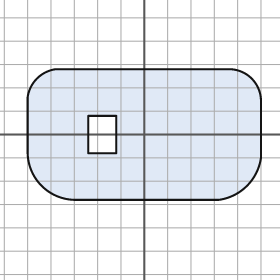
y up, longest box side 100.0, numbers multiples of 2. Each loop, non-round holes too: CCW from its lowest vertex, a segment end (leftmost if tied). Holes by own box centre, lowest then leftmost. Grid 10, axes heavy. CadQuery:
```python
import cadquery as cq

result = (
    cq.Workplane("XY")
    .moveTo(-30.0, -28.0)
    .lineTo(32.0, -28.0)
    .threePointArc((44.0, -22.0), (50.0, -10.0))
    .lineTo(50.0, 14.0)
    .threePointArc((46.0, 24.0), (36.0, 28.0))
    .lineTo(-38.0, 28.0)
    .threePointArc((-46.0, 24.0), (-50.0, 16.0))
    .lineTo(-50.0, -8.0)
    .threePointArc((-44.0, -22.0), (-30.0, -28.0))
    .close()
    .moveTo(-24.0, -8.0)
    .lineTo(-12.0, -8.0)
    .lineTo(-12.0, 8.0)
    .lineTo(-24.0, 8.0)
    .close()
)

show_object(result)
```